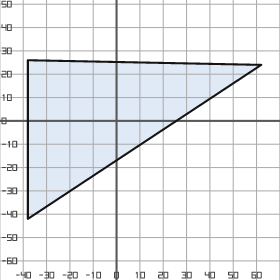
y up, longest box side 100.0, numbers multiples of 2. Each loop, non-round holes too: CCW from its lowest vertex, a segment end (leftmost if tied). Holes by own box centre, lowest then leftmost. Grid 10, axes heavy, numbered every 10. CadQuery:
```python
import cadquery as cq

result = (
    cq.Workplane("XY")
    .moveTo(-38.0, -42.0)
    .lineTo(62.0, 24.0)
    .lineTo(-38.0, 26.0)
    .close()
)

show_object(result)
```